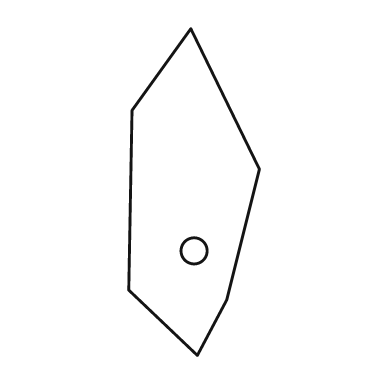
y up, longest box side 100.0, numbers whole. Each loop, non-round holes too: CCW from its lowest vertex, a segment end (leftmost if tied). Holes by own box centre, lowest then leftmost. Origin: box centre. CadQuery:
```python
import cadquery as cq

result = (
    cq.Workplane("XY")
    .moveTo(1.0, -50.0)
    .lineTo(10.0, -33.0)
    .lineTo(20.0, 7.0)
    .lineTo(-1.0, 50.0)
    .lineTo(-19.0, 25.0)
    .lineTo(-20.0, -30.0)
    .close()
    .moveTo(0.0, -18.0)
    .circle(4.0)
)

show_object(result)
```